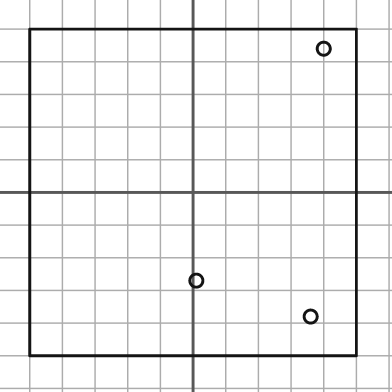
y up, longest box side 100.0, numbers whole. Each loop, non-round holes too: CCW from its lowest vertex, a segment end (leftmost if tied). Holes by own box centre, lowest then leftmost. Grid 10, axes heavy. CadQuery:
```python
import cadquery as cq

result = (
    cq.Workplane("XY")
    .moveTo(-50.0, -50.0)
    .lineTo(50.0, -50.0)
    .lineTo(50.0, 50.0)
    .lineTo(-50.0, 50.0)
    .close()
    .moveTo(36.0, -38.0)
    .circle(2.0)
    .moveTo(1.0, -27.0)
    .circle(2.0)
    .moveTo(40.0, 44.0)
    .circle(2.0)
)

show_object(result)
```